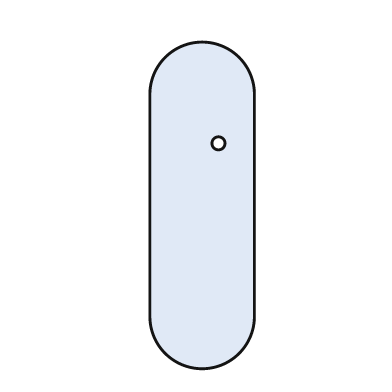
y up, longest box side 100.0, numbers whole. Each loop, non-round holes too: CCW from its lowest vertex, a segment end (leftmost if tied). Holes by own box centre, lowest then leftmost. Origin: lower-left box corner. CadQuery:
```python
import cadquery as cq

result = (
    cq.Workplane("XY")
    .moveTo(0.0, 16.0)
    .threePointArc((16.0, 0.0), (32.0, 16.0))
    .lineTo(32.0, 84.0)
    .threePointArc((16.0, 100.0), (0.0, 84.0))
    .close()
    .moveTo(21.0, 69.0)
    .circle(2.0)
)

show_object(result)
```